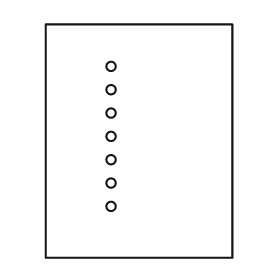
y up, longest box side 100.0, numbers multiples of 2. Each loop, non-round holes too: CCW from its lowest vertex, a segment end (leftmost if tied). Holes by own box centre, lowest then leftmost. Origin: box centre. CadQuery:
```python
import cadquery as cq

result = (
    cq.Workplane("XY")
    .moveTo(-40.0, -50.0)
    .lineTo(40.0, -50.0)
    .lineTo(40.0, 50.0)
    .lineTo(-40.0, 50.0)
    .close()
    .moveTo(-12.0, -28.0)
    .circle(2.0)
    .moveTo(-12.0, -18.0)
    .circle(2.0)
    .moveTo(-12.0, -8.0)
    .circle(2.0)
    .moveTo(-12.0, 2.0)
    .circle(2.0)
    .moveTo(-12.0, 12.0)
    .circle(2.0)
    .moveTo(-12.0, 22.0)
    .circle(2.0)
    .moveTo(-12.0, 32.0)
    .circle(2.0)
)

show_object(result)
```